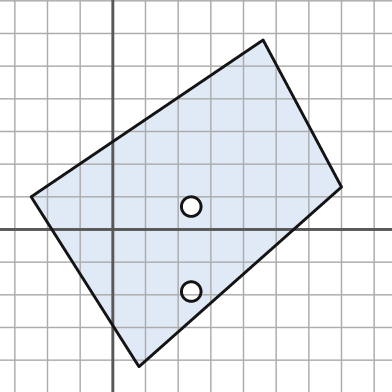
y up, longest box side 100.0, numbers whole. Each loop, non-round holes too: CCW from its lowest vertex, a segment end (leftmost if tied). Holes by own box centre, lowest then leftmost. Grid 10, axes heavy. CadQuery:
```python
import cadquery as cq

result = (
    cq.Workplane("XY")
    .moveTo(8.0, -42.0)
    .lineTo(70.0, 13.0)
    .lineTo(46.0, 58.0)
    .lineTo(-25.0, 10.0)
    .close()
    .moveTo(24.0, -19.0)
    .circle(3.0)
    .moveTo(24.0, 7.0)
    .circle(3.0)
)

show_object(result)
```